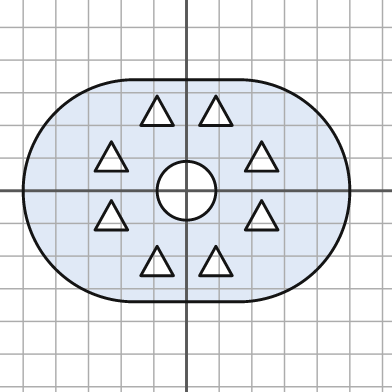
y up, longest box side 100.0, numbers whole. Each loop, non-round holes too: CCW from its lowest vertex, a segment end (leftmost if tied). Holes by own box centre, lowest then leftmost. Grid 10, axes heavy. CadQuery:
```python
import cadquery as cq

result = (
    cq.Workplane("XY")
    .moveTo(-16.0, -34.0)
    .lineTo(16.0, -34.0)
    .threePointArc((50.0, 0.0), (16.0, 34.0))
    .lineTo(-16.0, 34.0)
    .threePointArc((-50.0, 0.0), (-16.0, -34.0))
    .close()
    .moveTo(-14.0, -26.0)
    .lineTo(-4.0, -26.0)
    .lineTo(-9.0, -17.0)
    .close()
    .moveTo(4.0, -26.0)
    .lineTo(14.0, -26.0)
    .lineTo(9.0, -17.0)
    .close()
    .moveTo(-28.0, -12.0)
    .lineTo(-18.0, -12.0)
    .lineTo(-23.0, -3.0)
    .close()
    .moveTo(18.0, -12.0)
    .lineTo(28.0, -12.0)
    .lineTo(23.0, -3.0)
    .close()
    .moveTo(0.0, 0.0)
    .circle(9.0)
    .moveTo(-28.0, 6.0)
    .lineTo(-18.0, 6.0)
    .lineTo(-23.0, 15.0)
    .close()
    .moveTo(18.0, 6.0)
    .lineTo(28.0, 6.0)
    .lineTo(23.0, 15.0)
    .close()
    .moveTo(-14.0, 20.0)
    .lineTo(-4.0, 20.0)
    .lineTo(-9.0, 29.0)
    .close()
    .moveTo(4.0, 20.0)
    .lineTo(14.0, 20.0)
    .lineTo(9.0, 29.0)
    .close()
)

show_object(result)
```